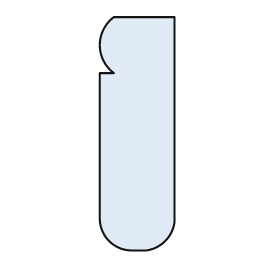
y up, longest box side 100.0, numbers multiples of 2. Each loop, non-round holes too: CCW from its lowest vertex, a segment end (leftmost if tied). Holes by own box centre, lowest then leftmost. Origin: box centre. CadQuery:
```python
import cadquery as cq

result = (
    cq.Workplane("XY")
    .moveTo(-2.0, -50.0)
    .lineTo(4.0, -50.0)
    .threePointArc((12.0, -46.0), (16.0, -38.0))
    .lineTo(16.0, 50.0)
    .lineTo(-10.0, 50.0)
    .threePointArc((-16.0, 38.0), (-10.0, 26.0))
    .lineTo(-16.0, 26.0)
    .lineTo(-16.0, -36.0)
    .threePointArc((-12.0, -46.0), (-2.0, -50.0))
    .close()
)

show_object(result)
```